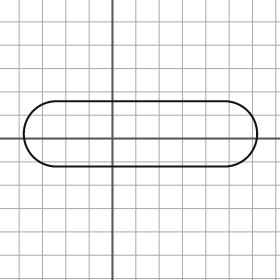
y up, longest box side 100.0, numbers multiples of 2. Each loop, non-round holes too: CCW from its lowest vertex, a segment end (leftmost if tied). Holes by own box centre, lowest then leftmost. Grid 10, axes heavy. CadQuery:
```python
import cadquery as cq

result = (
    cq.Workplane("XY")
    .moveTo(-24.0, -12.0)
    .lineTo(48.0, -12.0)
    .threePointArc((62.0, 2.0), (48.0, 16.0))
    .lineTo(-24.0, 16.0)
    .threePointArc((-38.0, 2.0), (-24.0, -12.0))
    .close()
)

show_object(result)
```